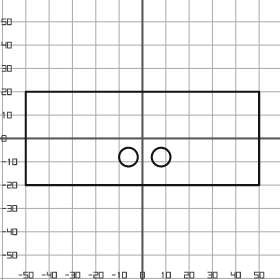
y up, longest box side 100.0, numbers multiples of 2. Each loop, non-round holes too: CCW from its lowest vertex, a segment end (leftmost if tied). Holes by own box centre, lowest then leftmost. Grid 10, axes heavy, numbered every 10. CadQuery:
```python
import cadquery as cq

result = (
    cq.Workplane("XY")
    .moveTo(-50.0, -20.0)
    .lineTo(50.0, -20.0)
    .lineTo(50.0, 20.0)
    .lineTo(-50.0, 20.0)
    .close()
    .moveTo(-6.0, -8.0)
    .circle(4.0)
    .moveTo(8.0, -8.0)
    .circle(4.0)
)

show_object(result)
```